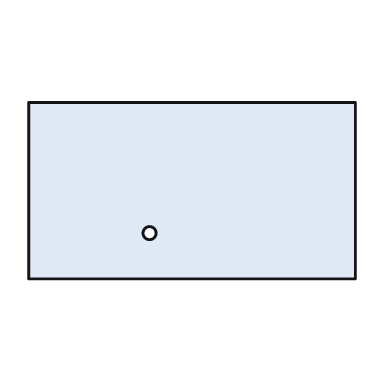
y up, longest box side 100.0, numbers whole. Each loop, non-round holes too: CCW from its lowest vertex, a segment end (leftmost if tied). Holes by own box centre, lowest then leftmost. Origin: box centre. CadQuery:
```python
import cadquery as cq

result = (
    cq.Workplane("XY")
    .moveTo(-50.0, -27.0)
    .lineTo(50.0, -27.0)
    .lineTo(50.0, 27.0)
    .lineTo(-50.0, 27.0)
    .close()
    .moveTo(-13.0, -13.0)
    .circle(2.0)
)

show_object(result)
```